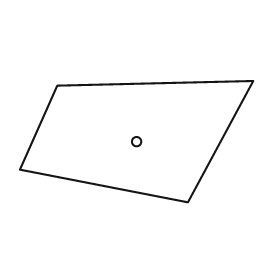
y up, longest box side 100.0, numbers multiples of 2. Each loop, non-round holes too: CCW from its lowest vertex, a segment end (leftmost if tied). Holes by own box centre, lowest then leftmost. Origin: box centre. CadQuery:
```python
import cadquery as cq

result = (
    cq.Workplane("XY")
    .moveTo(22.0, -26.0)
    .lineTo(50.0, 26.0)
    .lineTo(-34.0, 24.0)
    .lineTo(-50.0, -12.0)
    .close()
    .moveTo(0.0, 0.0)
    .circle(2.0)
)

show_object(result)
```